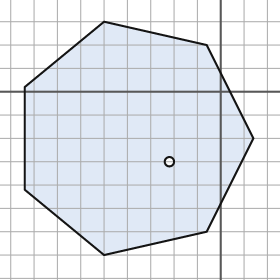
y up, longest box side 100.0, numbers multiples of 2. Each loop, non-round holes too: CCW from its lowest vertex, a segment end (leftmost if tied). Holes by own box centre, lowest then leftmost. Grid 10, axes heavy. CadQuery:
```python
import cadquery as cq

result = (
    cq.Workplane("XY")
    .moveTo(-50.0, -70.0)
    .lineTo(-6.0, -60.0)
    .lineTo(14.0, -20.0)
    .lineTo(-6.0, 20.0)
    .lineTo(-50.0, 30.0)
    .lineTo(-84.0, 2.0)
    .lineTo(-84.0, -42.0)
    .close()
    .moveTo(-22.0, -30.0)
    .circle(2.0)
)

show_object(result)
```